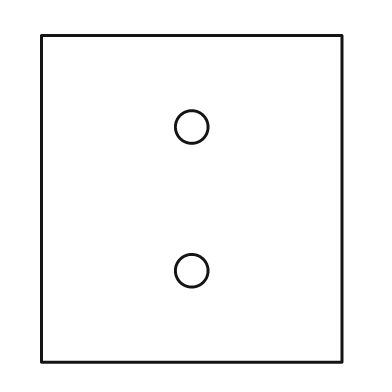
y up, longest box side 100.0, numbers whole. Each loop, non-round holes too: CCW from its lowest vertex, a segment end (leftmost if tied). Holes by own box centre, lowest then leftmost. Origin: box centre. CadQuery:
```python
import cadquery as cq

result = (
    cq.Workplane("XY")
    .moveTo(-46.0, -50.0)
    .lineTo(46.0, -50.0)
    .lineTo(46.0, 50.0)
    .lineTo(-46.0, 50.0)
    .close()
    .moveTo(0.0, -22.0)
    .circle(5.0)
    .moveTo(0.0, 22.0)
    .circle(5.0)
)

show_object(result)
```